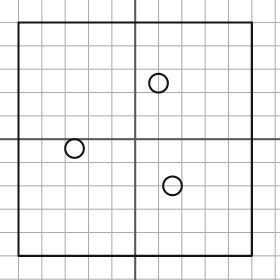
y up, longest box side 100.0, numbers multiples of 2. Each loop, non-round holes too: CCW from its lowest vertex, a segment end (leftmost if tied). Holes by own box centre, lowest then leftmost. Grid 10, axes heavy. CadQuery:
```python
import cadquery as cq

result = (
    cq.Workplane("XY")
    .moveTo(-50.0, -50.0)
    .lineTo(50.0, -50.0)
    .lineTo(50.0, 50.0)
    .lineTo(-50.0, 50.0)
    .close()
    .moveTo(16.0, -20.0)
    .circle(4.0)
    .moveTo(-26.0, -4.0)
    .circle(4.0)
    .moveTo(10.0, 24.0)
    .circle(4.0)
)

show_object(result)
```